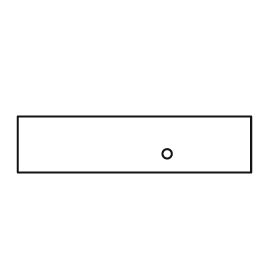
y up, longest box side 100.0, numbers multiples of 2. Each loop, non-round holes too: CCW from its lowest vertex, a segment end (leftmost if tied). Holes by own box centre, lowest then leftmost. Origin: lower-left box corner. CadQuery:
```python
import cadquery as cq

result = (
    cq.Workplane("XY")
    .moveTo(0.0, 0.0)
    .lineTo(100.0, 0.0)
    .lineTo(100.0, 24.0)
    .lineTo(0.0, 24.0)
    .close()
    .moveTo(64.0, 8.0)
    .circle(2.0)
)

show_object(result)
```